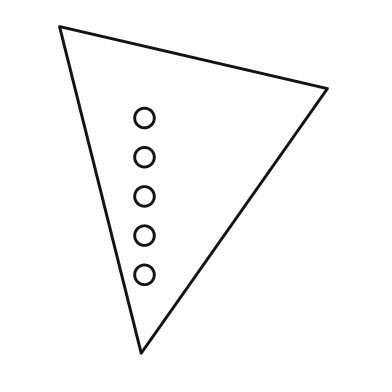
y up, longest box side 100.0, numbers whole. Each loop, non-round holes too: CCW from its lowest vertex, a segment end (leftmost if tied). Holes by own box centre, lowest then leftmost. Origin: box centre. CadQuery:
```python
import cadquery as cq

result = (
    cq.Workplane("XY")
    .moveTo(-16.0, -50.0)
    .lineTo(41.0, 31.0)
    .lineTo(-41.0, 50.0)
    .close()
    .moveTo(-15.0, -26.0)
    .circle(3.0)
    .moveTo(-15.0, -14.0)
    .circle(3.0)
    .moveTo(-15.0, -2.0)
    .circle(3.0)
    .moveTo(-15.0, 10.0)
    .circle(3.0)
    .moveTo(-15.0, 22.0)
    .circle(3.0)
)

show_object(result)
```